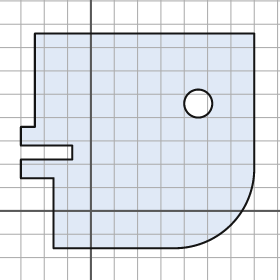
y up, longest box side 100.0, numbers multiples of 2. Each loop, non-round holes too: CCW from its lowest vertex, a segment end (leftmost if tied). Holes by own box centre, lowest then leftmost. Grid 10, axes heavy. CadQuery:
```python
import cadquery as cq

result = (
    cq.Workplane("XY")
    .moveTo(-16.0, -16.0)
    .lineTo(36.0, -16.0)
    .threePointArc((60.0, -6.0), (70.0, 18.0))
    .lineTo(70.0, 76.0)
    .lineTo(-24.0, 76.0)
    .lineTo(-24.0, 36.0)
    .lineTo(-30.0, 36.0)
    .lineTo(-30.0, 28.0)
    .lineTo(-8.0, 28.0)
    .lineTo(-8.0, 22.0)
    .lineTo(-30.0, 22.0)
    .lineTo(-30.0, 14.0)
    .lineTo(-16.0, 14.0)
    .close()
    .moveTo(46.0, 46.0)
    .circle(6.0)
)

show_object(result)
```